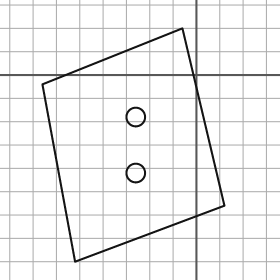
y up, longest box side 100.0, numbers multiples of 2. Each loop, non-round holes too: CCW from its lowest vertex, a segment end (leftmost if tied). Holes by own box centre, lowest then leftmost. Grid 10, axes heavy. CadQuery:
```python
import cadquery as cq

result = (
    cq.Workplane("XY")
    .moveTo(-52.0, -80.0)
    .lineTo(12.0, -56.0)
    .lineTo(-6.0, 20.0)
    .lineTo(-66.0, -4.0)
    .close()
    .moveTo(-26.0, -42.0)
    .circle(4.0)
    .moveTo(-26.0, -18.0)
    .circle(4.0)
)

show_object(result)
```